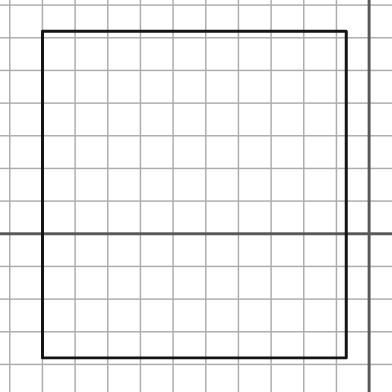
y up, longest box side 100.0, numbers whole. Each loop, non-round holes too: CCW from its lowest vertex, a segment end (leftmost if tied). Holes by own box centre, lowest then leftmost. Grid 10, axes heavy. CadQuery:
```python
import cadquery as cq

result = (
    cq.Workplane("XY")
    .moveTo(-100.0, -38.0)
    .lineTo(-7.0, -38.0)
    .lineTo(-7.0, 62.0)
    .lineTo(-100.0, 62.0)
    .close()
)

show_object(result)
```